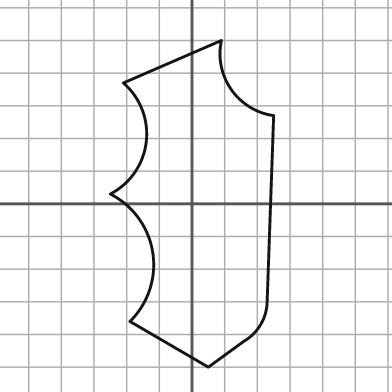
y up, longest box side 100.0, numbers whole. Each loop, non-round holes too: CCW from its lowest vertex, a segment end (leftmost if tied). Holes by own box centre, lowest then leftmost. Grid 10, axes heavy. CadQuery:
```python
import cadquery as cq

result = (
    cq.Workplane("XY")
    .moveTo(5.0, -50.0)
    .lineTo(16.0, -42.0)
    .threePointArc((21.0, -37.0), (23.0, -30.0))
    .lineTo(25.0, 27.0)
    .threePointArc((12.0, 35.0), (9.0, 50.0))
    .lineTo(-21.0, 37.0)
    .threePointArc((-14.0, 19.0), (-25.0, 3.0))
    .threePointArc((-12.0, -15.0), (-19.0, -36.0))
    .close()
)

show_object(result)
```